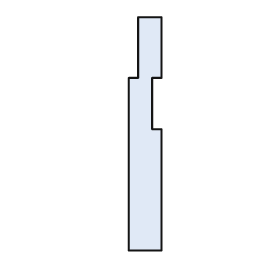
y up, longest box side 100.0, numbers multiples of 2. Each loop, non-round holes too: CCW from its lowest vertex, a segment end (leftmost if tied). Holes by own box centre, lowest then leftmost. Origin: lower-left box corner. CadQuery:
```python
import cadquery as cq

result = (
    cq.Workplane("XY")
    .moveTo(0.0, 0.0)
    .lineTo(14.0, 0.0)
    .lineTo(14.0, 52.0)
    .lineTo(10.0, 52.0)
    .lineTo(10.0, 74.0)
    .lineTo(14.0, 74.0)
    .lineTo(14.0, 100.0)
    .lineTo(4.0, 100.0)
    .lineTo(4.0, 74.0)
    .lineTo(0.0, 74.0)
    .close()
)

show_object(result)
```